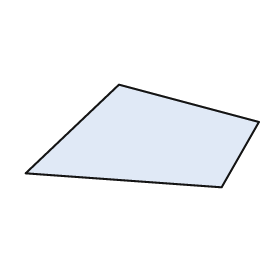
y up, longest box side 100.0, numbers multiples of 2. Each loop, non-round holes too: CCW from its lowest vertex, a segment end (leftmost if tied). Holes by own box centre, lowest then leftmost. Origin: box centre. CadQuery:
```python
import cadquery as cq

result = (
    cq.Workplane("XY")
    .moveTo(34.0, -22.0)
    .lineTo(50.0, 6.0)
    .lineTo(-10.0, 22.0)
    .lineTo(-50.0, -16.0)
    .close()
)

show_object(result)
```